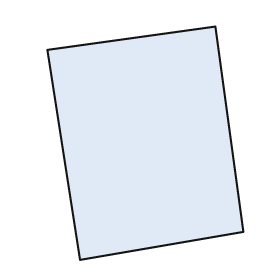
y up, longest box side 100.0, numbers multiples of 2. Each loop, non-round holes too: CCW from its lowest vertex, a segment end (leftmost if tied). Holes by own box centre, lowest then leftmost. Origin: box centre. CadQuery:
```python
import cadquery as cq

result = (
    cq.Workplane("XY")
    .moveTo(-28.0, -50.0)
    .lineTo(42.0, -38.0)
    .lineTo(30.0, 50.0)
    .lineTo(-42.0, 40.0)
    .close()
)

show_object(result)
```